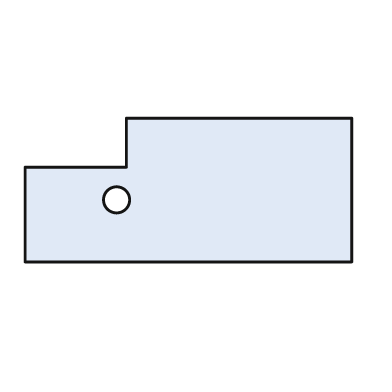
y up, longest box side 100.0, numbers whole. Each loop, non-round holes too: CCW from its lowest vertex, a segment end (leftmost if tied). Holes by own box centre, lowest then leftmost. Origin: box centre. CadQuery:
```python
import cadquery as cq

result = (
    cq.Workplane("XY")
    .moveTo(-50.0, -22.0)
    .lineTo(50.0, -22.0)
    .lineTo(50.0, 22.0)
    .lineTo(-19.0, 22.0)
    .lineTo(-19.0, 7.0)
    .lineTo(-50.0, 7.0)
    .close()
    .moveTo(-22.0, -3.0)
    .circle(4.0)
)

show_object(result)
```